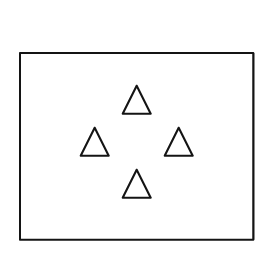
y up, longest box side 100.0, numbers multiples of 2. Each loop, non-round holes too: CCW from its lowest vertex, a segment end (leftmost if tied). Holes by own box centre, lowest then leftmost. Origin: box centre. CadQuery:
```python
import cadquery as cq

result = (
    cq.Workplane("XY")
    .moveTo(-50.0, -40.0)
    .lineTo(50.0, -40.0)
    .lineTo(50.0, 40.0)
    .lineTo(-50.0, 40.0)
    .close()
    .moveTo(-6.0, -22.0)
    .lineTo(6.0, -22.0)
    .lineTo(0.0, -10.0)
    .close()
    .moveTo(-24.0, -4.0)
    .lineTo(-12.0, -4.0)
    .lineTo(-18.0, 8.0)
    .close()
    .moveTo(12.0, -4.0)
    .lineTo(24.0, -4.0)
    .lineTo(18.0, 8.0)
    .close()
    .moveTo(-6.0, 14.0)
    .lineTo(6.0, 14.0)
    .lineTo(0.0, 26.0)
    .close()
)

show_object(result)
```